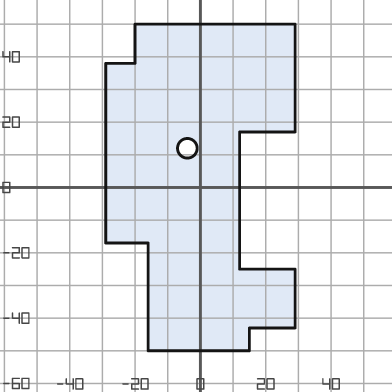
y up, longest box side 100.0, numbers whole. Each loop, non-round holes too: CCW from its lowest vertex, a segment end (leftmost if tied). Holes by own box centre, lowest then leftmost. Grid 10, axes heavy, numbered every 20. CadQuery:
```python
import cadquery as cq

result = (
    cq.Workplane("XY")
    .moveTo(-16.0, -50.0)
    .lineTo(15.0, -50.0)
    .lineTo(15.0, -43.0)
    .lineTo(29.0, -43.0)
    .lineTo(29.0, -25.0)
    .lineTo(12.0, -25.0)
    .lineTo(12.0, 17.0)
    .lineTo(29.0, 17.0)
    .lineTo(29.0, 50.0)
    .lineTo(-20.0, 50.0)
    .lineTo(-20.0, 38.0)
    .lineTo(-29.0, 38.0)
    .lineTo(-29.0, -17.0)
    .lineTo(-16.0, -17.0)
    .close()
    .moveTo(-4.0, 12.0)
    .circle(3.0)
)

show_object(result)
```